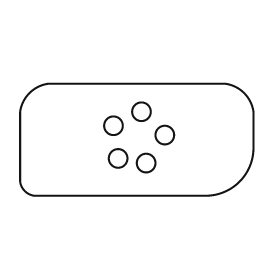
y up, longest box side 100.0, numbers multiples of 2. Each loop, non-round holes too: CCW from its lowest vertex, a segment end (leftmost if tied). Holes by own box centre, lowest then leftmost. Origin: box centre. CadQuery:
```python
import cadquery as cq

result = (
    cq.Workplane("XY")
    .moveTo(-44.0, -24.0)
    .lineTo(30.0, -24.0)
    .threePointArc((44.0, -18.0), (50.0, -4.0))
    .lineTo(50.0, 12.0)
    .threePointArc((46.0, 20.0), (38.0, 24.0))
    .lineTo(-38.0, 24.0)
    .threePointArc((-46.0, 20.0), (-50.0, 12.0))
    .lineTo(-50.0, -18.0)
    .threePointArc((-48.0, -22.0), (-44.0, -24.0))
    .close()
    .moveTo(4.0, -10.0)
    .circle(4.0)
    .moveTo(-8.0, -8.0)
    .circle(4.0)
    .moveTo(12.0, 2.0)
    .circle(4.0)
    .moveTo(-10.0, 6.0)
    .circle(4.0)
    .moveTo(2.0, 12.0)
    .circle(4.0)
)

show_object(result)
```